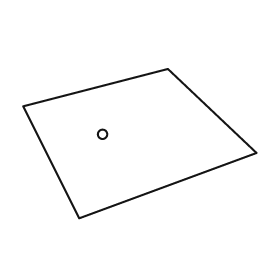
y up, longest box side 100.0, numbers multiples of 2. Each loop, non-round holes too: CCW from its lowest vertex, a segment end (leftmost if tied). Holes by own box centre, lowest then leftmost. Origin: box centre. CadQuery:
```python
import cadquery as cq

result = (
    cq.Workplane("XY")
    .moveTo(-26.0, -32.0)
    .lineTo(50.0, -4.0)
    .lineTo(12.0, 32.0)
    .lineTo(-50.0, 16.0)
    .close()
    .moveTo(-16.0, 4.0)
    .circle(2.0)
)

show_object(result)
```